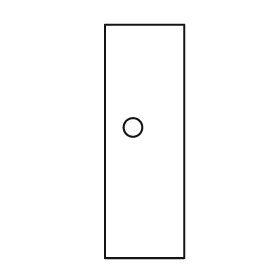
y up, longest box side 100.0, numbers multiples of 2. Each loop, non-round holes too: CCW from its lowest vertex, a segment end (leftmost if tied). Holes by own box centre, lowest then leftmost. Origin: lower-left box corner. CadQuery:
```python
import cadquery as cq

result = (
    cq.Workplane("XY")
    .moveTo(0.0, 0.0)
    .lineTo(34.0, 0.0)
    .lineTo(34.0, 100.0)
    .lineTo(0.0, 100.0)
    .close()
    .moveTo(12.0, 56.0)
    .circle(4.0)
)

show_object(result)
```